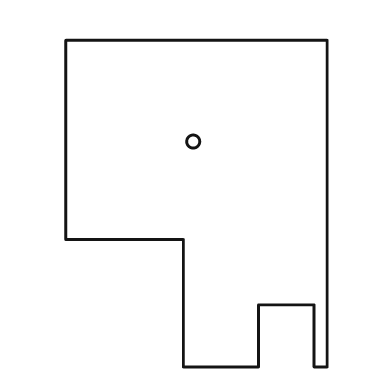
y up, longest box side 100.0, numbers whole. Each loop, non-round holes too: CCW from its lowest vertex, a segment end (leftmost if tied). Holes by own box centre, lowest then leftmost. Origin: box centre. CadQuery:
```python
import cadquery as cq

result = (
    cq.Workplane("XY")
    .moveTo(-4.0, -50.0)
    .lineTo(19.0, -50.0)
    .lineTo(19.0, -31.0)
    .lineTo(36.0, -31.0)
    .lineTo(36.0, -50.0)
    .lineTo(40.0, -50.0)
    .lineTo(40.0, 50.0)
    .lineTo(-40.0, 50.0)
    .lineTo(-40.0, -11.0)
    .lineTo(-4.0, -11.0)
    .close()
    .moveTo(-1.0, 19.0)
    .circle(2.0)
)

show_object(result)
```